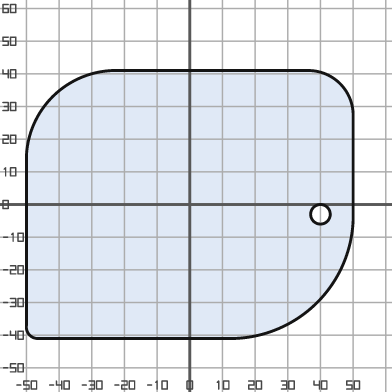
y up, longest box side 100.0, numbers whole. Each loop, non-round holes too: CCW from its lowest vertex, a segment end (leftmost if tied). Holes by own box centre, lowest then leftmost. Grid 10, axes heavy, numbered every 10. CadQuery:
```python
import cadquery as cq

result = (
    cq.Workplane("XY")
    .moveTo(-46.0, -41.0)
    .lineTo(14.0, -41.0)
    .threePointArc((39.0, -30.0), (50.0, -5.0))
    .lineTo(50.0, 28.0)
    .threePointArc((46.0, 37.0), (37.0, 41.0))
    .lineTo(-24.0, 41.0)
    .threePointArc((-42.0, 33.0), (-50.0, 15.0))
    .lineTo(-50.0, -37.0)
    .threePointArc((-49.0, -40.0), (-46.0, -41.0))
    .close()
    .moveTo(40.0, -3.0)
    .circle(3.0)
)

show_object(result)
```